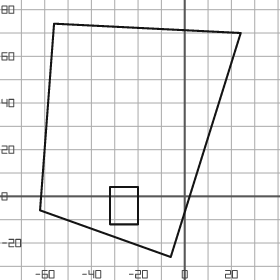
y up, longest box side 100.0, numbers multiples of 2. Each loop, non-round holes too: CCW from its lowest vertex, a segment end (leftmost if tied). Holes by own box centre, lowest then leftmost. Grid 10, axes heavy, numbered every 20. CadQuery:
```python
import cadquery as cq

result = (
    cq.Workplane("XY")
    .moveTo(-6.0, -26.0)
    .lineTo(24.0, 70.0)
    .lineTo(-56.0, 74.0)
    .lineTo(-62.0, -6.0)
    .close()
    .moveTo(-32.0, -12.0)
    .lineTo(-20.0, -12.0)
    .lineTo(-20.0, 4.0)
    .lineTo(-32.0, 4.0)
    .close()
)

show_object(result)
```